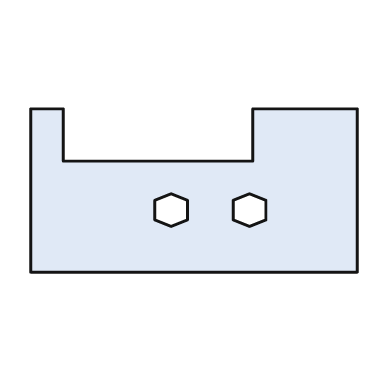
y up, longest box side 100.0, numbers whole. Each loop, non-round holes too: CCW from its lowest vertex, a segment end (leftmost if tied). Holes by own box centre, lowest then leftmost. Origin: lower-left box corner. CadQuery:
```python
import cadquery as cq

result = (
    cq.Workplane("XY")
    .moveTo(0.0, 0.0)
    .lineTo(100.0, 0.0)
    .lineTo(100.0, 50.0)
    .lineTo(68.0, 50.0)
    .lineTo(68.0, 34.0)
    .lineTo(10.0, 34.0)
    .lineTo(10.0, 50.0)
    .lineTo(0.0, 50.0)
    .close()
    .moveTo(43.0, 14.0)
    .lineTo(48.0, 16.0)
    .lineTo(48.0, 22.0)
    .lineTo(43.0, 24.0)
    .lineTo(38.0, 22.0)
    .lineTo(38.0, 16.0)
    .close()
    .moveTo(67.0, 14.0)
    .lineTo(72.0, 16.0)
    .lineTo(72.0, 22.0)
    .lineTo(67.0, 24.0)
    .lineTo(62.0, 22.0)
    .lineTo(62.0, 16.0)
    .close()
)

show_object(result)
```